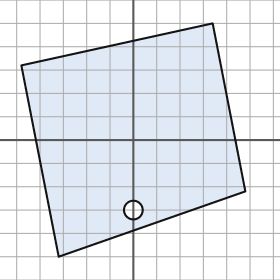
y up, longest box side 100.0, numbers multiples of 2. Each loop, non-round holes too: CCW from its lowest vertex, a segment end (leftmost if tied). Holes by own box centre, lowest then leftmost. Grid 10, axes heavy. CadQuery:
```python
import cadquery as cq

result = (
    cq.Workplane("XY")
    .moveTo(-32.0, -50.0)
    .lineTo(48.0, -22.0)
    .lineTo(34.0, 50.0)
    .lineTo(-48.0, 32.0)
    .close()
    .moveTo(0.0, -30.0)
    .circle(4.0)
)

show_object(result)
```